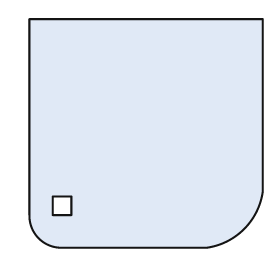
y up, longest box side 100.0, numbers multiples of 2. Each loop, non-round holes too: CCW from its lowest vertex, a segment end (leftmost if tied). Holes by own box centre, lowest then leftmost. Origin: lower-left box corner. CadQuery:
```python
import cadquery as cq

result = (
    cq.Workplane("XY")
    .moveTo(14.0, 0.0)
    .lineTo(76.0, 0.0)
    .threePointArc((92.0, 8.0), (100.0, 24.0))
    .lineTo(100.0, 98.0)
    .lineTo(0.0, 98.0)
    .lineTo(0.0, 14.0)
    .threePointArc((4.0, 4.0), (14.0, 0.0))
    .close()
    .moveTo(10.0, 14.0)
    .lineTo(18.0, 14.0)
    .lineTo(18.0, 22.0)
    .lineTo(10.0, 22.0)
    .close()
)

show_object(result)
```